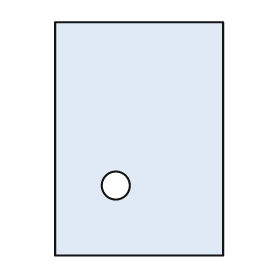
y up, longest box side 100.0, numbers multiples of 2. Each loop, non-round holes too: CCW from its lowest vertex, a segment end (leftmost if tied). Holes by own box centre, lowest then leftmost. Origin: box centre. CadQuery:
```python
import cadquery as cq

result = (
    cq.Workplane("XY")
    .moveTo(-36.0, -50.0)
    .lineTo(36.0, -50.0)
    .lineTo(36.0, 50.0)
    .lineTo(-36.0, 50.0)
    .close()
    .moveTo(-10.0, -20.0)
    .circle(6.0)
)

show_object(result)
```